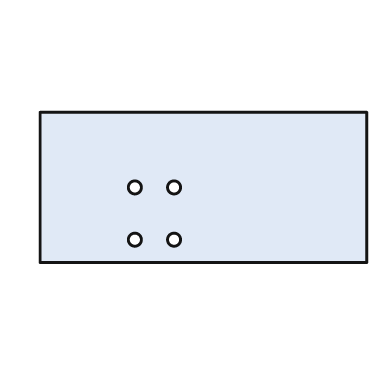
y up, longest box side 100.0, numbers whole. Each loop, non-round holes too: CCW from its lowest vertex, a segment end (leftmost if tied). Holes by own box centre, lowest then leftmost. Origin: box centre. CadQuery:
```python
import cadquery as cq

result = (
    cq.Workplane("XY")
    .moveTo(-50.0, -23.0)
    .lineTo(50.0, -23.0)
    .lineTo(50.0, 23.0)
    .lineTo(-50.0, 23.0)
    .close()
    .moveTo(-21.0, -16.0)
    .circle(2.0)
    .moveTo(-9.0, -16.0)
    .circle(2.0)
    .moveTo(-21.0, 0.0)
    .circle(2.0)
    .moveTo(-9.0, 0.0)
    .circle(2.0)
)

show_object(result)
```